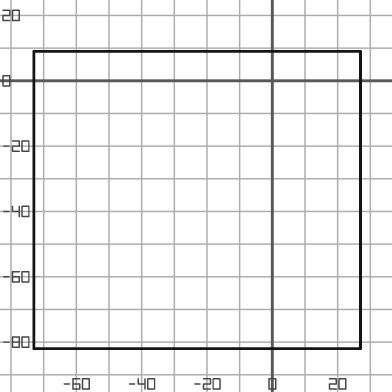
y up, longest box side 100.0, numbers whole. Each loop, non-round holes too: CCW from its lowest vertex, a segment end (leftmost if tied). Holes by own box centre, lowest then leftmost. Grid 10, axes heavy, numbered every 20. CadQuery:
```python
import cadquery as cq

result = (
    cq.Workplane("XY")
    .moveTo(-73.0, -82.0)
    .lineTo(27.0, -82.0)
    .lineTo(27.0, 9.0)
    .lineTo(-73.0, 9.0)
    .close()
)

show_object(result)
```